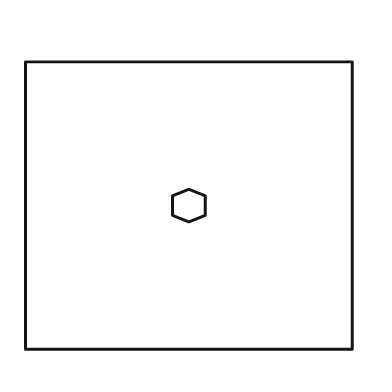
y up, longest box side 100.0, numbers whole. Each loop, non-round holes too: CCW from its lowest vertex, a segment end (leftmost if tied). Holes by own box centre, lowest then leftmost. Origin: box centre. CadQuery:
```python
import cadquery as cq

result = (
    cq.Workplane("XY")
    .moveTo(-50.0, -44.0)
    .lineTo(50.0, -44.0)
    .lineTo(50.0, 44.0)
    .lineTo(-50.0, 44.0)
    .close()
    .moveTo(0.0, -5.0)
    .lineTo(5.0, -3.0)
    .lineTo(5.0, 3.0)
    .lineTo(0.0, 5.0)
    .lineTo(-5.0, 3.0)
    .lineTo(-5.0, -3.0)
    .close()
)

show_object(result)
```